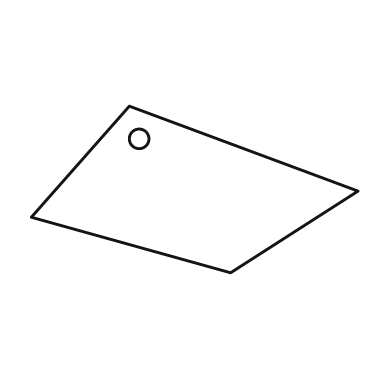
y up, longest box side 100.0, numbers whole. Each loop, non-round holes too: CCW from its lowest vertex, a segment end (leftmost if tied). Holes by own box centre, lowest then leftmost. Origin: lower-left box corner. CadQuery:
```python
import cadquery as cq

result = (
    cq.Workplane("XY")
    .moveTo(61.0, 0.0)
    .lineTo(100.0, 25.0)
    .lineTo(30.0, 51.0)
    .lineTo(0.0, 17.0)
    .close()
    .moveTo(33.0, 41.0)
    .circle(3.0)
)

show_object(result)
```